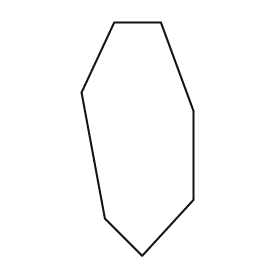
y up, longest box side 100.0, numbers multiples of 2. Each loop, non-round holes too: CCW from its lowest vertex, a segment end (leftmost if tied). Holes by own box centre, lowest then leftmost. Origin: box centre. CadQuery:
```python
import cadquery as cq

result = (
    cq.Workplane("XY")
    .moveTo(2.0, -50.0)
    .lineTo(24.0, -26.0)
    .lineTo(24.0, 12.0)
    .lineTo(10.0, 50.0)
    .lineTo(-10.0, 50.0)
    .lineTo(-24.0, 20.0)
    .lineTo(-14.0, -34.0)
    .close()
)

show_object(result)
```